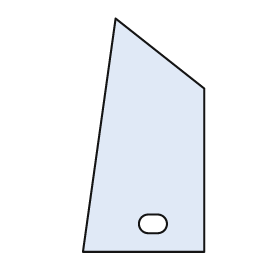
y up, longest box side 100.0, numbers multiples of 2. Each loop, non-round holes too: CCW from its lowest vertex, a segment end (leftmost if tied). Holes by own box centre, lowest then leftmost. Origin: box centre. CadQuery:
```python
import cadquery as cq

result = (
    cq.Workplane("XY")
    .moveTo(-26.0, -50.0)
    .lineTo(26.0, -50.0)
    .lineTo(26.0, 20.0)
    .lineTo(-12.0, 50.0)
    .close()
    .moveTo(2.0, -42.0)
    .lineTo(6.0, -42.0)
    .threePointArc((10.0, -38.0), (6.0, -34.0))
    .lineTo(2.0, -34.0)
    .threePointArc((-2.0, -38.0), (2.0, -42.0))
    .close()
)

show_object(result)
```